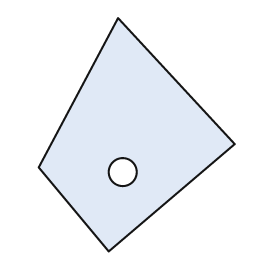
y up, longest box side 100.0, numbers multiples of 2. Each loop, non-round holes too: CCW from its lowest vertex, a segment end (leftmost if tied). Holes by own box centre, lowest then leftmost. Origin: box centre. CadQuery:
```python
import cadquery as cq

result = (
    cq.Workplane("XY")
    .moveTo(-12.0, -50.0)
    .lineTo(42.0, -4.0)
    .lineTo(-8.0, 50.0)
    .lineTo(-42.0, -14.0)
    .close()
    .moveTo(-6.0, -16.0)
    .circle(6.0)
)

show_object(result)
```